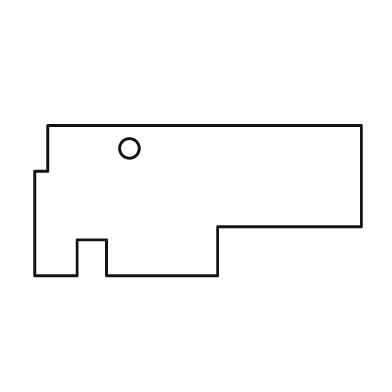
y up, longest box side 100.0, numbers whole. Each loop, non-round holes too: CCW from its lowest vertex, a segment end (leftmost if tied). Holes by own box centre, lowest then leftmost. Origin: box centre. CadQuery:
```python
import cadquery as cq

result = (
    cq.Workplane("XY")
    .moveTo(-50.0, -23.0)
    .lineTo(-37.0, -23.0)
    .lineTo(-37.0, -12.0)
    .lineTo(-28.0, -12.0)
    .lineTo(-28.0, -23.0)
    .lineTo(6.0, -23.0)
    .lineTo(6.0, -8.0)
    .lineTo(50.0, -8.0)
    .lineTo(50.0, 23.0)
    .lineTo(-46.0, 23.0)
    .lineTo(-46.0, 9.0)
    .lineTo(-50.0, 9.0)
    .close()
    .moveTo(-21.0, 16.0)
    .circle(3.0)
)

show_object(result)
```